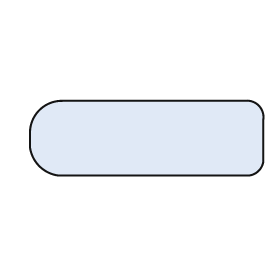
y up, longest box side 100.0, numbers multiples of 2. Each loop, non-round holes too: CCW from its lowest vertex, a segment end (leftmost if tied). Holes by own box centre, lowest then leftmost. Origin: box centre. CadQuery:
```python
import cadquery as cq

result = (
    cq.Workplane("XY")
    .moveTo(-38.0, -16.0)
    .lineTo(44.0, -16.0)
    .threePointArc((48.0, -14.0), (50.0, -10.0))
    .lineTo(50.0, 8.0)
    .threePointArc((48.0, 14.0), (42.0, 16.0))
    .lineTo(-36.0, 16.0)
    .threePointArc((-46.0, 12.0), (-50.0, 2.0))
    .lineTo(-50.0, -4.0)
    .threePointArc((-46.0, -12.0), (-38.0, -16.0))
    .close()
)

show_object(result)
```